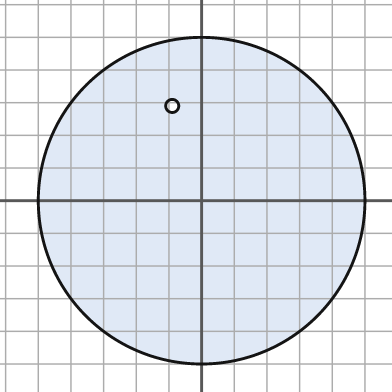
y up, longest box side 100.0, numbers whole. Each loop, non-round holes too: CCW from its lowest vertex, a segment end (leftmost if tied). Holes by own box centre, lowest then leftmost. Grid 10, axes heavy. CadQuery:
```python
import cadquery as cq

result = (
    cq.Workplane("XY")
    .moveTo(0.0, 0.0)
    .circle(50.0)
    .moveTo(-9.0, 29.0)
    .circle(2.0)
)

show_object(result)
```